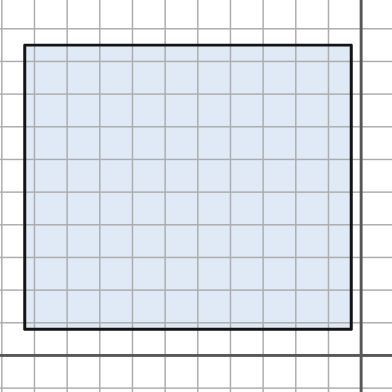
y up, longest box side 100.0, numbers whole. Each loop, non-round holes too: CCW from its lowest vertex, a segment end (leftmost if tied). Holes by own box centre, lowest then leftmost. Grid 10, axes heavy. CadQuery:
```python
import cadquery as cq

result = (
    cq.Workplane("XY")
    .moveTo(-103.0, 8.0)
    .lineTo(-3.0, 8.0)
    .lineTo(-3.0, 95.0)
    .lineTo(-103.0, 95.0)
    .close()
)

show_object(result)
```